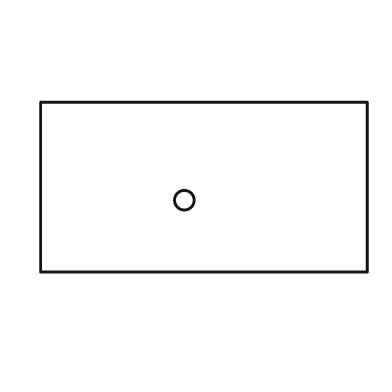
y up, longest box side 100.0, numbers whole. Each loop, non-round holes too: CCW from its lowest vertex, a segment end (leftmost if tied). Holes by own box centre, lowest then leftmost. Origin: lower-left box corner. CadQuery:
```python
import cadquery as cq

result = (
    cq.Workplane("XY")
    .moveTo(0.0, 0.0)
    .lineTo(100.0, 0.0)
    .lineTo(100.0, 52.0)
    .lineTo(0.0, 52.0)
    .close()
    .moveTo(44.0, 22.0)
    .circle(3.0)
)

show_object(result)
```